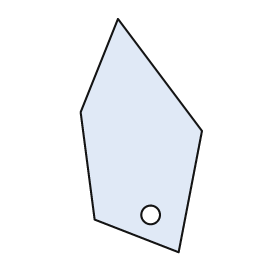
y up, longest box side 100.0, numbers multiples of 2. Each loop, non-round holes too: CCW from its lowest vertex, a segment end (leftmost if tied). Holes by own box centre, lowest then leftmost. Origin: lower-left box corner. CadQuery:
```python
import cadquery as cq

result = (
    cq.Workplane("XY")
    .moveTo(42.0, 0.0)
    .lineTo(52.0, 52.0)
    .lineTo(16.0, 100.0)
    .lineTo(0.0, 60.0)
    .lineTo(6.0, 14.0)
    .close()
    .moveTo(30.0, 16.0)
    .circle(4.0)
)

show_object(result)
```